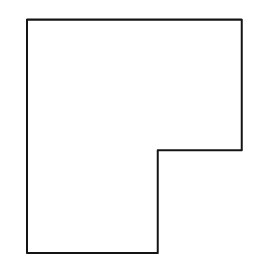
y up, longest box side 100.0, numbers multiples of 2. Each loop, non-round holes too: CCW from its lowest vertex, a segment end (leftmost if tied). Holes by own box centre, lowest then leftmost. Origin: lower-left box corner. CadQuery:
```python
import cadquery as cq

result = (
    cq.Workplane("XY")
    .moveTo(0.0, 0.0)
    .lineTo(56.0, 0.0)
    .lineTo(56.0, 44.0)
    .lineTo(92.0, 44.0)
    .lineTo(92.0, 100.0)
    .lineTo(0.0, 100.0)
    .close()
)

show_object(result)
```